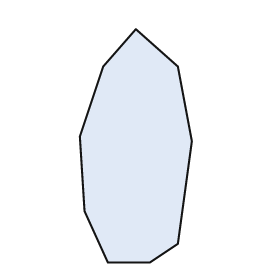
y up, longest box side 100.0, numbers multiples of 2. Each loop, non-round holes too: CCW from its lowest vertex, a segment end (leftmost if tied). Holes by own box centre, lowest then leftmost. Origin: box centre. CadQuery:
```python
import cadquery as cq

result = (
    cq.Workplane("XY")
    .moveTo(-12.0, -50.0)
    .lineTo(6.0, -50.0)
    .lineTo(18.0, -42.0)
    .lineTo(24.0, 2.0)
    .lineTo(18.0, 34.0)
    .lineTo(0.0, 50.0)
    .lineTo(-14.0, 34.0)
    .lineTo(-24.0, 4.0)
    .lineTo(-22.0, -28.0)
    .close()
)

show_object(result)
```